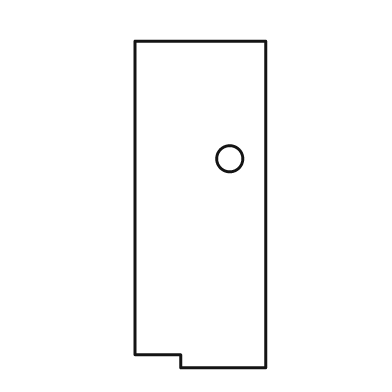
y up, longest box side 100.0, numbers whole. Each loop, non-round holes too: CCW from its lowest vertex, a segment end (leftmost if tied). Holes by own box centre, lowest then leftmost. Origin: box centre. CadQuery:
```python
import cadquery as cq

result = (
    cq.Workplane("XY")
    .moveTo(-6.0, -50.0)
    .lineTo(20.0, -50.0)
    .lineTo(20.0, 50.0)
    .lineTo(-20.0, 50.0)
    .lineTo(-20.0, -46.0)
    .lineTo(-6.0, -46.0)
    .close()
    .moveTo(9.0, 14.0)
    .circle(4.0)
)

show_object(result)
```